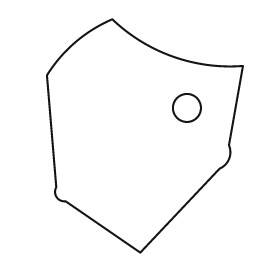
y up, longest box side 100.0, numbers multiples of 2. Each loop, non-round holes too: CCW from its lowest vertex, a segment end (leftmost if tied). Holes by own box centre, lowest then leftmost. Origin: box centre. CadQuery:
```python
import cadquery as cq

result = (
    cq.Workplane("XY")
    .moveTo(-2.0, -50.0)
    .lineTo(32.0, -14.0)
    .threePointArc((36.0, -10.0), (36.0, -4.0))
    .lineTo(42.0, 30.0)
    .threePointArc((12.0, 34.0), (-14.0, 50.0))
    .threePointArc((-30.0, 40.0), (-42.0, 26.0))
    .lineTo(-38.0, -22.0)
    .threePointArc((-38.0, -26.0), (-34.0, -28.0))
    .close()
    .moveTo(18.0, 12.0)
    .circle(6.0)
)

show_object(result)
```